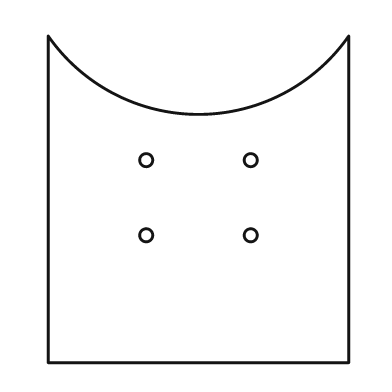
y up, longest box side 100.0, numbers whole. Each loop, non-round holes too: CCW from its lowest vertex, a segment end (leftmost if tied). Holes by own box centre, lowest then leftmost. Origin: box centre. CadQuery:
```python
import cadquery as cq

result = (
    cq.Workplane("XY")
    .moveTo(-46.0, -50.0)
    .lineTo(46.0, -50.0)
    .lineTo(46.0, 50.0)
    .threePointArc((0.0, 26.0), (-46.0, 50.0))
    .close()
    .moveTo(-16.0, -11.0)
    .circle(2.0)
    .moveTo(16.0, -11.0)
    .circle(2.0)
    .moveTo(-16.0, 12.0)
    .circle(2.0)
    .moveTo(16.0, 12.0)
    .circle(2.0)
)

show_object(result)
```